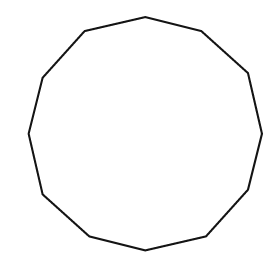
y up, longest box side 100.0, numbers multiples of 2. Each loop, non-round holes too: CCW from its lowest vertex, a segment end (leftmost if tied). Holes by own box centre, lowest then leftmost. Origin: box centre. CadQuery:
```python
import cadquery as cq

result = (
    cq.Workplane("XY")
    .moveTo(0.0, -50.0)
    .lineTo(26.0, -44.0)
    .lineTo(44.0, -24.0)
    .lineTo(50.0, 0.0)
    .lineTo(44.0, 26.0)
    .lineTo(24.0, 44.0)
    .lineTo(0.0, 50.0)
    .lineTo(-26.0, 44.0)
    .lineTo(-44.0, 24.0)
    .lineTo(-50.0, 0.0)
    .lineTo(-44.0, -26.0)
    .lineTo(-24.0, -44.0)
    .close()
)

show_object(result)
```